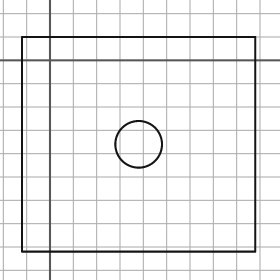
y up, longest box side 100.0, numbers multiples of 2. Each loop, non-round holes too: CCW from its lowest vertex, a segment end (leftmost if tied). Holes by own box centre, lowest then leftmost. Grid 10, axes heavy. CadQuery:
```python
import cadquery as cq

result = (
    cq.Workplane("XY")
    .moveTo(-12.0, -82.0)
    .lineTo(88.0, -82.0)
    .lineTo(88.0, 10.0)
    .lineTo(-12.0, 10.0)
    .close()
    .moveTo(38.0, -36.0)
    .circle(10.0)
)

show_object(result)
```